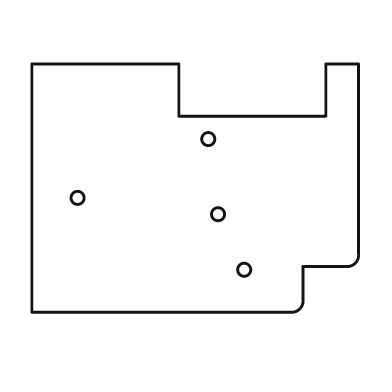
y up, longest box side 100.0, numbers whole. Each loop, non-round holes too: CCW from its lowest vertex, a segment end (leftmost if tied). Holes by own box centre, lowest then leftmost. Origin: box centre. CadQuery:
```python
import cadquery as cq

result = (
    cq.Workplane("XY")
    .moveTo(-50.0, -38.0)
    .lineTo(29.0, -38.0)
    .threePointArc((32.0, -37.0), (33.0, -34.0))
    .lineTo(33.0, -24.0)
    .lineTo(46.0, -24.0)
    .threePointArc((49.0, -23.0), (50.0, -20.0))
    .lineTo(50.0, 38.0)
    .lineTo(40.0, 38.0)
    .lineTo(40.0, 22.0)
    .lineTo(-5.0, 22.0)
    .lineTo(-5.0, 38.0)
    .lineTo(-50.0, 38.0)
    .close()
    .moveTo(15.0, -25.0)
    .circle(2.0)
    .moveTo(7.0, -8.0)
    .circle(2.0)
    .moveTo(-36.0, -3.0)
    .circle(2.0)
    .moveTo(4.0, 15.0)
    .circle(2.0)
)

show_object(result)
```